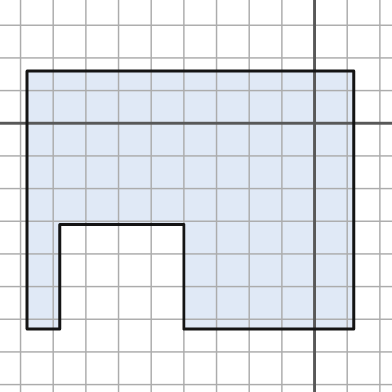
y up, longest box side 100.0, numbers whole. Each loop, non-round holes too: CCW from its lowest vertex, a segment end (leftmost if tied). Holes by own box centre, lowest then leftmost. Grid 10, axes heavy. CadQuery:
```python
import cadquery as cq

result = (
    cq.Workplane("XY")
    .moveTo(-88.0, -63.0)
    .lineTo(-78.0, -63.0)
    .lineTo(-78.0, -31.0)
    .lineTo(-40.0, -31.0)
    .lineTo(-40.0, -63.0)
    .lineTo(12.0, -63.0)
    .lineTo(12.0, 16.0)
    .lineTo(-88.0, 16.0)
    .close()
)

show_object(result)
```